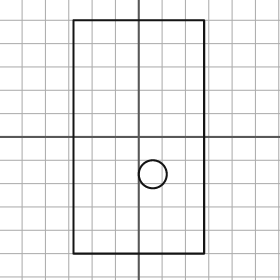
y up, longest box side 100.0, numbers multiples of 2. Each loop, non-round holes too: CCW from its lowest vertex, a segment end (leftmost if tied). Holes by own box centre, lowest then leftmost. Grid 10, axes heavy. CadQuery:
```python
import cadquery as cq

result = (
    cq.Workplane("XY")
    .moveTo(-28.0, -50.0)
    .lineTo(28.0, -50.0)
    .lineTo(28.0, 50.0)
    .lineTo(-28.0, 50.0)
    .close()
    .moveTo(6.0, -16.0)
    .circle(6.0)
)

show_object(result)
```